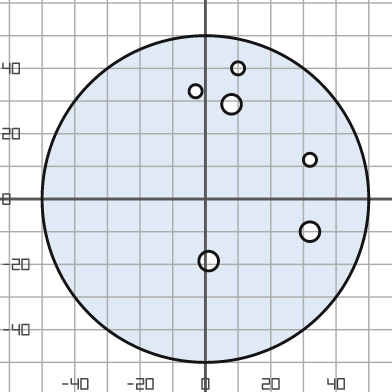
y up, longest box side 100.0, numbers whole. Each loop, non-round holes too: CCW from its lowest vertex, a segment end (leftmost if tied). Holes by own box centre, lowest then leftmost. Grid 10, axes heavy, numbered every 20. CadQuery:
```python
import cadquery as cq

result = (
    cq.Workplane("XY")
    .moveTo(0.0, 0.0)
    .circle(50.0)
    .moveTo(1.0, -19.0)
    .circle(3.0)
    .moveTo(32.0, -10.0)
    .circle(3.0)
    .moveTo(32.0, 12.0)
    .circle(2.0)
    .moveTo(8.0, 29.0)
    .circle(3.0)
    .moveTo(-3.0, 33.0)
    .circle(2.0)
    .moveTo(10.0, 40.0)
    .circle(2.0)
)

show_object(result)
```